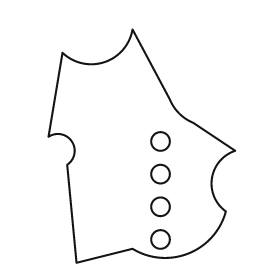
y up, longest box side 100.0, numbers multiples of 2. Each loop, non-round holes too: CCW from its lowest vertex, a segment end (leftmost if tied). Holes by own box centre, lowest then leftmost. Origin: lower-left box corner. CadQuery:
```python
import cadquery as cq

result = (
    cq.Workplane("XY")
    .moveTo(12.0, 0.0)
    .lineTo(36.0, 6.0)
    .threePointArc((60.0, 4.0), (76.0, 22.0))
    .threePointArc((70.0, 36.0), (80.0, 48.0))
    .lineTo(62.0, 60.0)
    .threePointArc((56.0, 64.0), (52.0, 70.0))
    .lineTo(36.0, 100.0)
    .threePointArc((24.0, 86.0), (6.0, 90.0))
    .lineTo(0.0, 54.0)
    .threePointArc((10.0, 52.0), (8.0, 42.0))
    .close()
    .moveTo(48.0, 10.0)
    .circle(4.0)
    .moveTo(48.0, 24.0)
    .circle(4.0)
    .moveTo(48.0, 38.0)
    .circle(4.0)
    .moveTo(48.0, 52.0)
    .circle(4.0)
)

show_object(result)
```